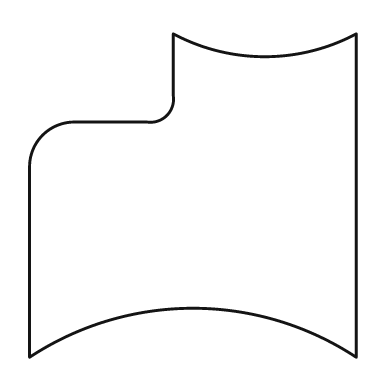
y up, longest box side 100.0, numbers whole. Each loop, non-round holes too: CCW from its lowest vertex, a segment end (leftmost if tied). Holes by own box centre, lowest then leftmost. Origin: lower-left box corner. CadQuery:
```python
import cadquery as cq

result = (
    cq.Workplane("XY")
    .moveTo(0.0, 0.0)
    .threePointArc((50.0, 15.0), (100.0, 0.0))
    .lineTo(100.0, 99.0)
    .threePointArc((72.0, 92.0), (44.0, 99.0))
    .lineTo(44.0, 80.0)
    .threePointArc((42.0, 74.0), (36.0, 72.0))
    .lineTo(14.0, 72.0)
    .threePointArc((4.0, 68.0), (0.0, 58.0))
    .close()
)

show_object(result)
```